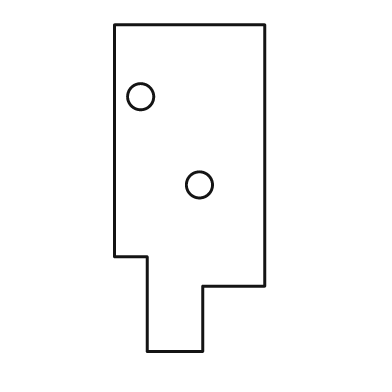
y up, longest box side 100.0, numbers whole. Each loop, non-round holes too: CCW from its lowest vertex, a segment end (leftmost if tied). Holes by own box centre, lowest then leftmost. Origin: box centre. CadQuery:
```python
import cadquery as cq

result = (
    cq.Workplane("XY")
    .moveTo(-13.0, -50.0)
    .lineTo(4.0, -50.0)
    .lineTo(4.0, -30.0)
    .lineTo(23.0, -30.0)
    .lineTo(23.0, 50.0)
    .lineTo(-23.0, 50.0)
    .lineTo(-23.0, -21.0)
    .lineTo(-13.0, -21.0)
    .close()
    .moveTo(3.0, 1.0)
    .circle(4.0)
    .moveTo(-15.0, 28.0)
    .circle(4.0)
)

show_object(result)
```